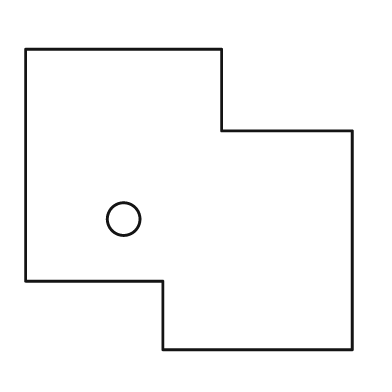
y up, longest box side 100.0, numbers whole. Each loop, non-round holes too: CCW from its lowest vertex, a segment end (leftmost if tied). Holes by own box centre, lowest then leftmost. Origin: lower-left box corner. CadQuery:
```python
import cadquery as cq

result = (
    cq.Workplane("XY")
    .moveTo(42.0, 0.0)
    .lineTo(100.0, 0.0)
    .lineTo(100.0, 67.0)
    .lineTo(60.0, 67.0)
    .lineTo(60.0, 92.0)
    .lineTo(0.0, 92.0)
    .lineTo(0.0, 21.0)
    .lineTo(42.0, 21.0)
    .close()
    .moveTo(30.0, 40.0)
    .circle(5.0)
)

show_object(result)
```